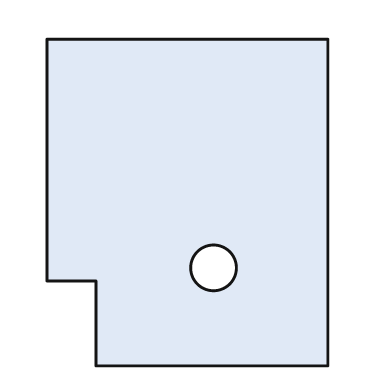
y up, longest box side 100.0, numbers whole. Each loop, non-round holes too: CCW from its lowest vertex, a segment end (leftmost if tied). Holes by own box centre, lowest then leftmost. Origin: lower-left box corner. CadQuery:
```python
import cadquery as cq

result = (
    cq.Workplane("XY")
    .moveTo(15.0, 0.0)
    .lineTo(86.0, 0.0)
    .lineTo(86.0, 100.0)
    .lineTo(0.0, 100.0)
    .lineTo(0.0, 26.0)
    .lineTo(15.0, 26.0)
    .close()
    .moveTo(51.0, 30.0)
    .circle(7.0)
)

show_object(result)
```